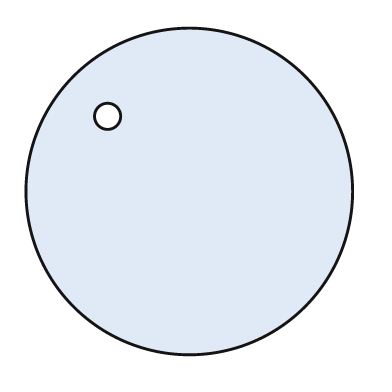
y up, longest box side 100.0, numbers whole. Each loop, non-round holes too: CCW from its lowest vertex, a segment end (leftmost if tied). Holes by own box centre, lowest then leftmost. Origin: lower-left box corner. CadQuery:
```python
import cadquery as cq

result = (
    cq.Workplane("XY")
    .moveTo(50.0, 50.0)
    .circle(50.0)
    .moveTo(25.0, 73.0)
    .circle(4.0)
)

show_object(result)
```